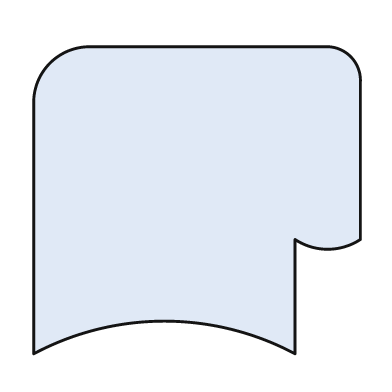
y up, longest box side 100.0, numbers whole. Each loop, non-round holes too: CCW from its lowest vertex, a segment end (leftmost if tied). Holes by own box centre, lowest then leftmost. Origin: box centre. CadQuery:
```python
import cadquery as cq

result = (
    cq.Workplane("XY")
    .moveTo(-50.0, -47.0)
    .threePointArc((-10.0, -37.0), (30.0, -47.0))
    .lineTo(30.0, -12.0)
    .threePointArc((40.0, -15.0), (50.0, -12.0))
    .lineTo(50.0, 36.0)
    .threePointArc((47.0, 44.0), (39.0, 47.0))
    .lineTo(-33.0, 47.0)
    .threePointArc((-45.0, 42.0), (-50.0, 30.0))
    .close()
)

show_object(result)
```